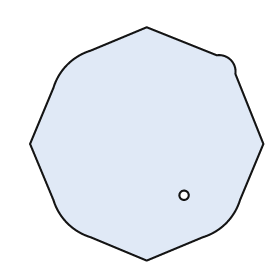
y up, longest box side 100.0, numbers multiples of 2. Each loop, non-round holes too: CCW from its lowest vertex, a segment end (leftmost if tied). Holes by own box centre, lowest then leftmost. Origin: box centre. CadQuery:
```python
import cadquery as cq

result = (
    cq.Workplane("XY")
    .moveTo(0.0, -50.0)
    .lineTo(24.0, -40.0)
    .threePointArc((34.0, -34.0), (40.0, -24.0))
    .lineTo(50.0, 0.0)
    .lineTo(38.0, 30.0)
    .threePointArc((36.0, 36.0), (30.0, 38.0))
    .lineTo(0.0, 50.0)
    .lineTo(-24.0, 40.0)
    .threePointArc((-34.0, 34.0), (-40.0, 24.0))
    .lineTo(-50.0, 0.0)
    .lineTo(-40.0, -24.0)
    .threePointArc((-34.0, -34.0), (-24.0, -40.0))
    .close()
    .moveTo(16.0, -22.0)
    .circle(2.0)
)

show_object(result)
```